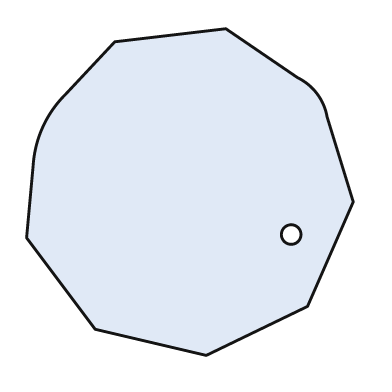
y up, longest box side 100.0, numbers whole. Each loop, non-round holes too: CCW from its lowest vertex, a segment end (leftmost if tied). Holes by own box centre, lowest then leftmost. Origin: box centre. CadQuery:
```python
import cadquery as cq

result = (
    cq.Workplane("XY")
    .moveTo(5.0, -50.0)
    .lineTo(36.0, -35.0)
    .lineTo(50.0, -3.0)
    .lineTo(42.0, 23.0)
    .threePointArc((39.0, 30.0), (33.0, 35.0))
    .lineTo(11.0, 50.0)
    .lineTo(-23.0, 46.0)
    .lineTo(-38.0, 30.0)
    .threePointArc((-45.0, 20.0), (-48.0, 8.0))
    .lineTo(-50.0, -14.0)
    .lineTo(-29.0, -42.0)
    .close()
    .moveTo(31.0, -13.0)
    .circle(3.0)
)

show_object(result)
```